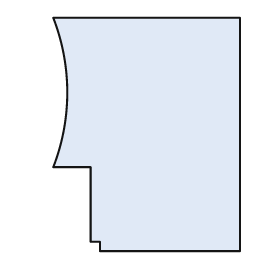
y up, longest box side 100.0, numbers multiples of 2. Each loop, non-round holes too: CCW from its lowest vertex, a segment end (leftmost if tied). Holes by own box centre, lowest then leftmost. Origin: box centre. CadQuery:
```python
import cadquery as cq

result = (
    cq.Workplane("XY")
    .moveTo(-20.0, -50.0)
    .lineTo(40.0, -50.0)
    .lineTo(40.0, 50.0)
    .lineTo(-40.0, 50.0)
    .threePointArc((-34.0, 18.0), (-40.0, -14.0))
    .lineTo(-24.0, -14.0)
    .lineTo(-24.0, -46.0)
    .lineTo(-20.0, -46.0)
    .close()
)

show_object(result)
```